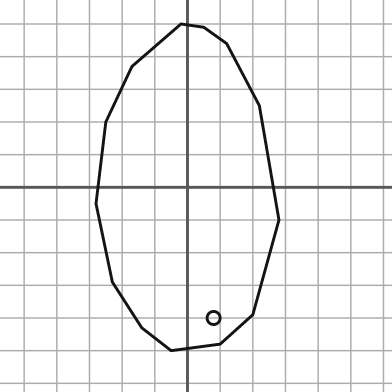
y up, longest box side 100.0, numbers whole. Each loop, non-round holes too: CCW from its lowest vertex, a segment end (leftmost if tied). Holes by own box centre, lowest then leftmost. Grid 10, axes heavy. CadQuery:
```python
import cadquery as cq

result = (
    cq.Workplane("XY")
    .moveTo(-5.0, -50.0)
    .lineTo(10.0, -48.0)
    .lineTo(20.0, -39.0)
    .lineTo(28.0, -10.0)
    .lineTo(22.0, 25.0)
    .lineTo(12.0, 44.0)
    .lineTo(5.0, 49.0)
    .lineTo(-2.0, 50.0)
    .lineTo(-17.0, 37.0)
    .lineTo(-25.0, 20.0)
    .lineTo(-28.0, -5.0)
    .lineTo(-23.0, -29.0)
    .lineTo(-14.0, -43.0)
    .close()
    .moveTo(8.0, -40.0)
    .circle(2.0)
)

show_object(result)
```